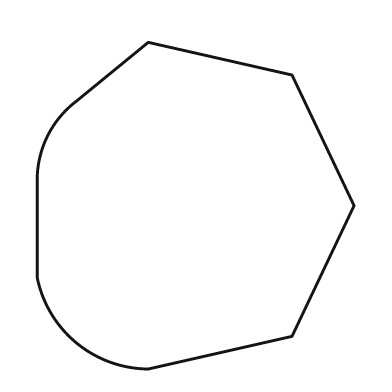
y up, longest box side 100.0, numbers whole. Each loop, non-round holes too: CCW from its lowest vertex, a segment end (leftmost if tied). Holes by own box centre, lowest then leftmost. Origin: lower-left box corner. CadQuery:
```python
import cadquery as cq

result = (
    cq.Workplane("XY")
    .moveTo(34.0, 0.0)
    .lineTo(78.0, 10.0)
    .lineTo(97.0, 50.0)
    .lineTo(78.0, 90.0)
    .lineTo(34.0, 100.0)
    .lineTo(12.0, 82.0)
    .threePointArc((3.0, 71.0), (0.0, 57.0))
    .lineTo(0.0, 28.0)
    .threePointArc((12.0, 8.0), (34.0, 0.0))
    .close()
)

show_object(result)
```